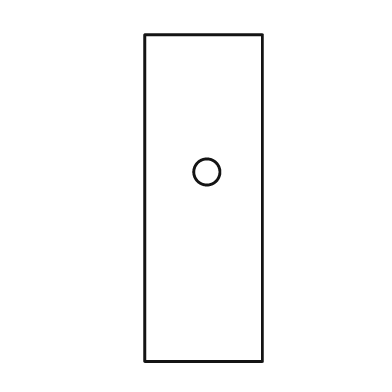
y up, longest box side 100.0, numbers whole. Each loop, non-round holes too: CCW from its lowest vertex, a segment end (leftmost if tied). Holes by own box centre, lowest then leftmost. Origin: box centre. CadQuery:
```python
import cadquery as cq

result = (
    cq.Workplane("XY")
    .moveTo(-18.0, -50.0)
    .lineTo(18.0, -50.0)
    .lineTo(18.0, 50.0)
    .lineTo(-18.0, 50.0)
    .close()
    .moveTo(1.0, 8.0)
    .circle(4.0)
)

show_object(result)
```